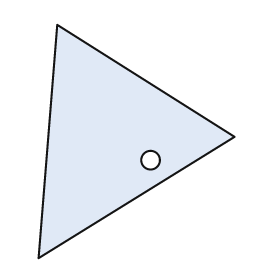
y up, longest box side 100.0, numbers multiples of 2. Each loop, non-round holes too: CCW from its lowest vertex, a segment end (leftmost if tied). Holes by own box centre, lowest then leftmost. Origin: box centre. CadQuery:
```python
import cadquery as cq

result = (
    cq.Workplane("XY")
    .moveTo(-42.0, -50.0)
    .lineTo(42.0, 2.0)
    .lineTo(-34.0, 50.0)
    .close()
    .moveTo(6.0, -8.0)
    .circle(4.0)
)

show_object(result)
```